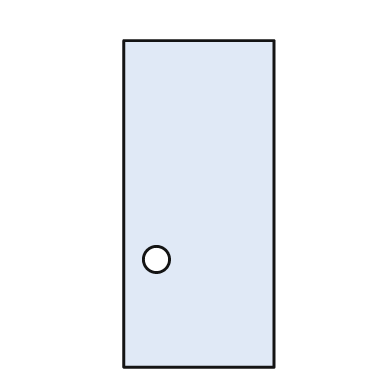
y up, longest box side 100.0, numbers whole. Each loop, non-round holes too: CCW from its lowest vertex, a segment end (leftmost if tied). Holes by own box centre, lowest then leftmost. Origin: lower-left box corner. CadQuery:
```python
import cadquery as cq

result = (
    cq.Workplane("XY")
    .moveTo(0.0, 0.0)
    .lineTo(46.0, 0.0)
    .lineTo(46.0, 100.0)
    .lineTo(0.0, 100.0)
    .close()
    .moveTo(10.0, 33.0)
    .circle(4.0)
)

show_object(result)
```